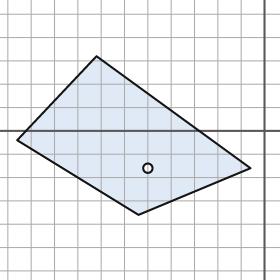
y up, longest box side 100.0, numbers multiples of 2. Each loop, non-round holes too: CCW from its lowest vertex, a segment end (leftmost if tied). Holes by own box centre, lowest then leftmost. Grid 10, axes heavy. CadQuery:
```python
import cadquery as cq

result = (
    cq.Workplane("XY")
    .moveTo(-54.0, -36.0)
    .lineTo(-6.0, -16.0)
    .lineTo(-72.0, 32.0)
    .lineTo(-106.0, -4.0)
    .close()
    .moveTo(-50.0, -16.0)
    .circle(2.0)
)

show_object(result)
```